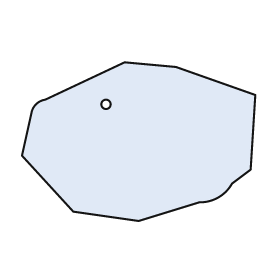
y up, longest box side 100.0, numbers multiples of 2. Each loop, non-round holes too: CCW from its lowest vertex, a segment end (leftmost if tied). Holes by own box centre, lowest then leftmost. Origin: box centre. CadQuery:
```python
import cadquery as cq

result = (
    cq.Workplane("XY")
    .moveTo(0.0, -34.0)
    .lineTo(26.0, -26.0)
    .threePointArc((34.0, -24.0), (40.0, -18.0))
    .lineTo(48.0, -12.0)
    .lineTo(50.0, 20.0)
    .lineTo(16.0, 32.0)
    .lineTo(-6.0, 34.0)
    .lineTo(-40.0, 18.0)
    .threePointArc((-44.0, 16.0), (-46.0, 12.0))
    .lineTo(-50.0, -6.0)
    .lineTo(-28.0, -30.0)
    .close()
    .moveTo(-14.0, 16.0)
    .circle(2.0)
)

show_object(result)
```